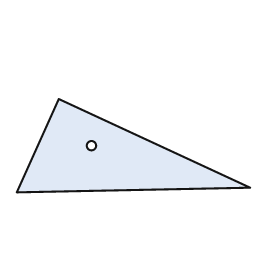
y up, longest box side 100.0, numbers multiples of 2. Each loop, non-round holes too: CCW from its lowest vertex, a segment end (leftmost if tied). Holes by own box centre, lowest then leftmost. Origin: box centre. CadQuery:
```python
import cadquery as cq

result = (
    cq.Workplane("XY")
    .moveTo(-50.0, -20.0)
    .lineTo(50.0, -18.0)
    .lineTo(-32.0, 20.0)
    .close()
    .moveTo(-18.0, 0.0)
    .circle(2.0)
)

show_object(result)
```